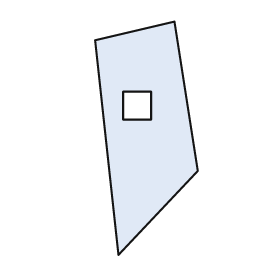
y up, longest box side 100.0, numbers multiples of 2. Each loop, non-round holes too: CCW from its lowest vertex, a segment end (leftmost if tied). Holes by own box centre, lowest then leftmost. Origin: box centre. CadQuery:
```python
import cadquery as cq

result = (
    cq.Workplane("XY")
    .moveTo(-12.0, -50.0)
    .lineTo(22.0, -14.0)
    .lineTo(12.0, 50.0)
    .lineTo(-22.0, 42.0)
    .close()
    .moveTo(-10.0, 8.0)
    .lineTo(2.0, 8.0)
    .lineTo(2.0, 20.0)
    .lineTo(-10.0, 20.0)
    .close()
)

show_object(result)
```